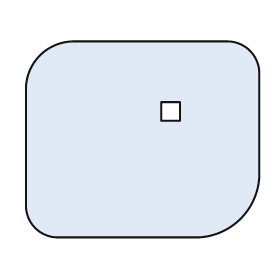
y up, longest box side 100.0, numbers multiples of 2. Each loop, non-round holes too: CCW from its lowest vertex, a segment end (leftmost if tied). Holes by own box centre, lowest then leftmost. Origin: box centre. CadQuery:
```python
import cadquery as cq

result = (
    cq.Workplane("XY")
    .moveTo(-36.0, -42.0)
    .lineTo(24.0, -42.0)
    .threePointArc((42.0, -34.0), (50.0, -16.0))
    .lineTo(50.0, 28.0)
    .threePointArc((46.0, 38.0), (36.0, 42.0))
    .lineTo(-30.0, 42.0)
    .threePointArc((-44.0, 36.0), (-50.0, 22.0))
    .lineTo(-50.0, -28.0)
    .threePointArc((-46.0, -38.0), (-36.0, -42.0))
    .close()
    .moveTo(8.0, 8.0)
    .lineTo(16.0, 8.0)
    .lineTo(16.0, 16.0)
    .lineTo(8.0, 16.0)
    .close()
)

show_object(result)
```